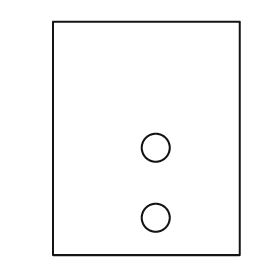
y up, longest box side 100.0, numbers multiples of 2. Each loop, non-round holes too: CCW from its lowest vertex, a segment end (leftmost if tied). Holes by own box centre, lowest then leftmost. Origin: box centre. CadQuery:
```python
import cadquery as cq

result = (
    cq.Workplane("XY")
    .moveTo(-40.0, -50.0)
    .lineTo(40.0, -50.0)
    .lineTo(40.0, 50.0)
    .lineTo(-40.0, 50.0)
    .close()
    .moveTo(4.0, -34.0)
    .circle(6.0)
    .moveTo(4.0, -4.0)
    .circle(6.0)
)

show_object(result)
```